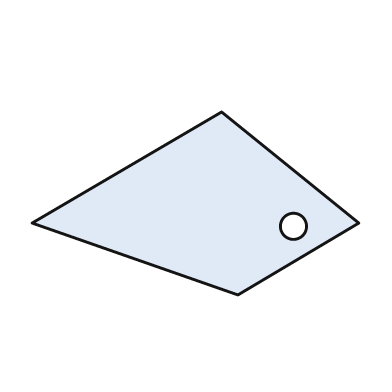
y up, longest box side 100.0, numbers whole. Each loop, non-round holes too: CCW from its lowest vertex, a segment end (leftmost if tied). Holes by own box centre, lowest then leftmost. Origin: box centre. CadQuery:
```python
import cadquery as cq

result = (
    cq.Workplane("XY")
    .moveTo(13.0, -28.0)
    .lineTo(50.0, -6.0)
    .lineTo(8.0, 28.0)
    .lineTo(-50.0, -6.0)
    .close()
    .moveTo(30.0, -7.0)
    .circle(4.0)
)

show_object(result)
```